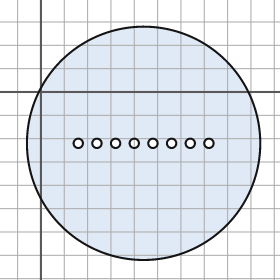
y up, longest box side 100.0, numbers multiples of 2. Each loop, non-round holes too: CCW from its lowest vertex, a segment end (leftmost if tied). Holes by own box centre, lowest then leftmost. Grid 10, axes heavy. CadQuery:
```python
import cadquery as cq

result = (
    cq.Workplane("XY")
    .moveTo(44.0, -22.0)
    .circle(50.0)
    .moveTo(16.0, -22.0)
    .circle(2.0)
    .moveTo(24.0, -22.0)
    .circle(2.0)
    .moveTo(32.0, -22.0)
    .circle(2.0)
    .moveTo(40.0, -22.0)
    .circle(2.0)
    .moveTo(48.0, -22.0)
    .circle(2.0)
    .moveTo(56.0, -22.0)
    .circle(2.0)
    .moveTo(64.0, -22.0)
    .circle(2.0)
    .moveTo(72.0, -22.0)
    .circle(2.0)
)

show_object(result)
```